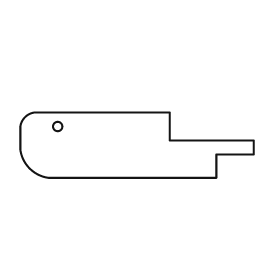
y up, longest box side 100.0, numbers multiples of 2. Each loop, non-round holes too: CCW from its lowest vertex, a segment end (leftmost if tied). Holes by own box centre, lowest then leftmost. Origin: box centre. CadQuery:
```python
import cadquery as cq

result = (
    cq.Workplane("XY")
    .moveTo(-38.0, -14.0)
    .lineTo(34.0, -14.0)
    .lineTo(34.0, -4.0)
    .lineTo(50.0, -4.0)
    .lineTo(50.0, 2.0)
    .lineTo(14.0, 2.0)
    .lineTo(14.0, 14.0)
    .lineTo(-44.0, 14.0)
    .threePointArc((-48.0, 12.0), (-50.0, 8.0))
    .lineTo(-50.0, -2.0)
    .threePointArc((-46.0, -10.0), (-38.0, -14.0))
    .close()
    .moveTo(-34.0, 8.0)
    .circle(2.0)
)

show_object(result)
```